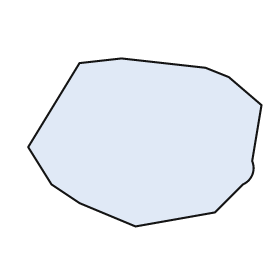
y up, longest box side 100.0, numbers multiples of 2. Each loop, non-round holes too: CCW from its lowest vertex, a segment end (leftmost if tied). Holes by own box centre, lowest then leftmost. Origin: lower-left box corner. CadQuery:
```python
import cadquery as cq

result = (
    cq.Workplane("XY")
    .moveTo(46.0, 0.0)
    .lineTo(80.0, 6.0)
    .lineTo(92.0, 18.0)
    .threePointArc((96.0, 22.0), (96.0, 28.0))
    .lineTo(100.0, 52.0)
    .lineTo(86.0, 64.0)
    .lineTo(76.0, 68.0)
    .lineTo(40.0, 72.0)
    .lineTo(22.0, 70.0)
    .lineTo(0.0, 34.0)
    .lineTo(10.0, 18.0)
    .lineTo(22.0, 10.0)
    .close()
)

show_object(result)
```